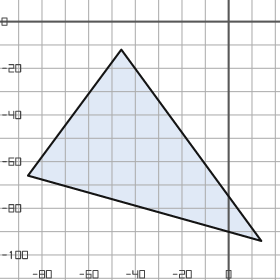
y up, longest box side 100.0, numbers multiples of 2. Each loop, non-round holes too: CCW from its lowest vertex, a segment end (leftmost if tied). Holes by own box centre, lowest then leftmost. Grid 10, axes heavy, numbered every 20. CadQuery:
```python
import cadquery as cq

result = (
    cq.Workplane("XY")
    .moveTo(14.0, -94.0)
    .lineTo(-46.0, -12.0)
    .lineTo(-86.0, -66.0)
    .close()
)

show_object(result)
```